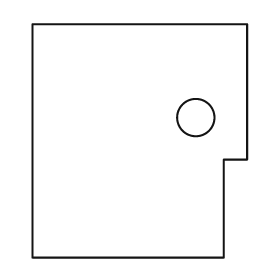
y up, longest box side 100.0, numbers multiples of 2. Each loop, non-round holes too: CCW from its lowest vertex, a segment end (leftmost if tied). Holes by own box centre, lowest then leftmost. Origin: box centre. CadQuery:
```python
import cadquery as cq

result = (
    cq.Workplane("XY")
    .moveTo(-46.0, -50.0)
    .lineTo(36.0, -50.0)
    .lineTo(36.0, -8.0)
    .lineTo(46.0, -8.0)
    .lineTo(46.0, 50.0)
    .lineTo(-46.0, 50.0)
    .close()
    .moveTo(24.0, 10.0)
    .circle(8.0)
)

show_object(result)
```